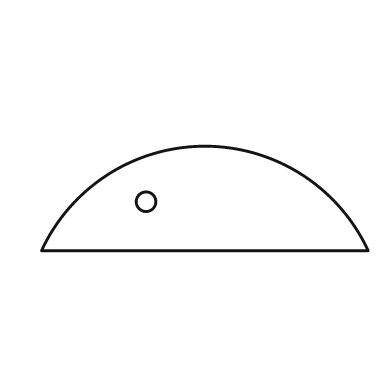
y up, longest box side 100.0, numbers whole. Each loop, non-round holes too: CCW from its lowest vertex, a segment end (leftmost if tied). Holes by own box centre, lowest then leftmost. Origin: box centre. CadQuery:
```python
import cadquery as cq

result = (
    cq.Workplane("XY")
    .moveTo(-50.0, -16.0)
    .lineTo(50.0, -16.0)
    .threePointArc((0.0, 16.0), (-50.0, -16.0))
    .close()
    .moveTo(-18.0, -1.0)
    .circle(3.0)
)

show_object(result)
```